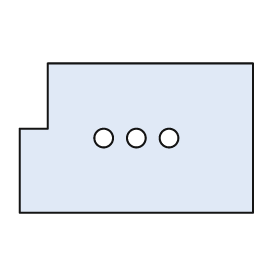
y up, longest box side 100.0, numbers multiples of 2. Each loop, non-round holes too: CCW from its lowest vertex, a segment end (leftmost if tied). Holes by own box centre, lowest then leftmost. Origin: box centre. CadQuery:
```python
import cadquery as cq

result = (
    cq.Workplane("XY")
    .moveTo(-50.0, -32.0)
    .lineTo(50.0, -32.0)
    .lineTo(50.0, 32.0)
    .lineTo(-38.0, 32.0)
    .lineTo(-38.0, 4.0)
    .lineTo(-50.0, 4.0)
    .close()
    .moveTo(-14.0, 0.0)
    .circle(4.0)
    .moveTo(0.0, 0.0)
    .circle(4.0)
    .moveTo(14.0, 0.0)
    .circle(4.0)
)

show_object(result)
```